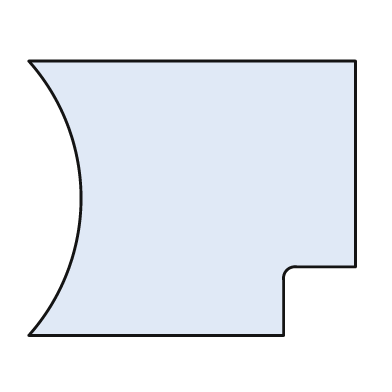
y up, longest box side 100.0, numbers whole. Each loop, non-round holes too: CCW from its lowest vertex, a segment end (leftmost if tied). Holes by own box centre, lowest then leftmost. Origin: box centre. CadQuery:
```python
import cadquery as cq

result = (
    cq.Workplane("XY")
    .moveTo(-50.0, -42.0)
    .lineTo(28.0, -42.0)
    .lineTo(28.0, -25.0)
    .threePointArc((29.0, -22.0), (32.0, -21.0))
    .lineTo(50.0, -21.0)
    .lineTo(50.0, 42.0)
    .lineTo(-50.0, 42.0)
    .threePointArc((-34.0, 0.0), (-50.0, -42.0))
    .close()
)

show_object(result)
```